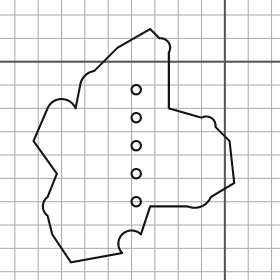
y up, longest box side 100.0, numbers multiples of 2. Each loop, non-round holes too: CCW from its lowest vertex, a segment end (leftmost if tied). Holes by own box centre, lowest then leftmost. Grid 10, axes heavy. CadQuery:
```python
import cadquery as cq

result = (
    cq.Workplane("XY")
    .moveTo(-66.0, -86.0)
    .lineTo(-44.0, -82.0)
    .threePointArc((-44.0, -74.0), (-36.0, -74.0))
    .lineTo(-32.0, -62.0)
    .lineTo(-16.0, -62.0)
    .threePointArc((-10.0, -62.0), (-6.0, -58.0))
    .lineTo(4.0, -52.0)
    .lineTo(2.0, -34.0)
    .lineTo(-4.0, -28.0)
    .threePointArc((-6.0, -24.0), (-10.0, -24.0))
    .lineTo(-24.0, -20.0)
    .lineTo(-24.0, 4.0)
    .threePointArc((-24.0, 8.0), (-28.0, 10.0))
    .lineTo(-32.0, 14.0)
    .lineTo(-46.0, 6.0)
    .lineTo(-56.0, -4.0)
    .threePointArc((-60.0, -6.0), (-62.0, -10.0))
    .lineTo(-64.0, -20.0)
    .threePointArc((-70.0, -16.0), (-76.0, -20.0))
    .lineTo(-82.0, -34.0)
    .lineTo(-72.0, -48.0)
    .lineTo(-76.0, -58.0)
    .threePointArc((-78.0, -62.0), (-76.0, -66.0))
    .lineTo(-74.0, -74.0)
    .close()
    .moveTo(-38.0, -60.0)
    .circle(2.0)
    .moveTo(-38.0, -48.0)
    .circle(2.0)
    .moveTo(-38.0, -36.0)
    .circle(2.0)
    .moveTo(-38.0, -24.0)
    .circle(2.0)
    .moveTo(-38.0, -12.0)
    .circle(2.0)
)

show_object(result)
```